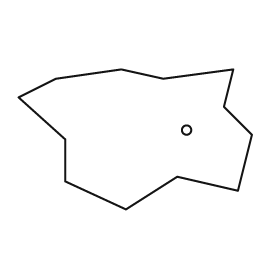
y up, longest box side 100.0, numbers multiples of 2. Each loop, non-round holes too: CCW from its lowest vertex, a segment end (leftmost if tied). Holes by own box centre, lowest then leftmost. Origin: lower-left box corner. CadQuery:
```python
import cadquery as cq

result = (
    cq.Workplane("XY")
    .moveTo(46.0, 0.0)
    .lineTo(68.0, 14.0)
    .lineTo(94.0, 8.0)
    .lineTo(100.0, 32.0)
    .lineTo(88.0, 44.0)
    .lineTo(92.0, 60.0)
    .lineTo(62.0, 56.0)
    .lineTo(44.0, 60.0)
    .lineTo(16.0, 56.0)
    .lineTo(0.0, 48.0)
    .lineTo(20.0, 30.0)
    .lineTo(20.0, 12.0)
    .close()
    .moveTo(72.0, 34.0)
    .circle(2.0)
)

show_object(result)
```